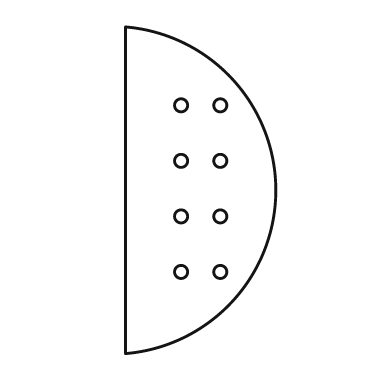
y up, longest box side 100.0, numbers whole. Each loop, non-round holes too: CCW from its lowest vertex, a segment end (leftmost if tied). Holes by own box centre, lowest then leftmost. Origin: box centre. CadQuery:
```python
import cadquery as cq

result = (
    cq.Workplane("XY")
    .moveTo(-23.0, -50.0)
    .threePointArc((23.0, 0.0), (-23.0, 50.0))
    .close()
    .moveTo(-6.0, -25.0)
    .circle(2.0)
    .moveTo(6.0, -25.0)
    .circle(2.0)
    .moveTo(-6.0, -8.0)
    .circle(2.0)
    .moveTo(6.0, -8.0)
    .circle(2.0)
    .moveTo(-6.0, 9.0)
    .circle(2.0)
    .moveTo(6.0, 9.0)
    .circle(2.0)
    .moveTo(-6.0, 26.0)
    .circle(2.0)
    .moveTo(6.0, 26.0)
    .circle(2.0)
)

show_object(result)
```